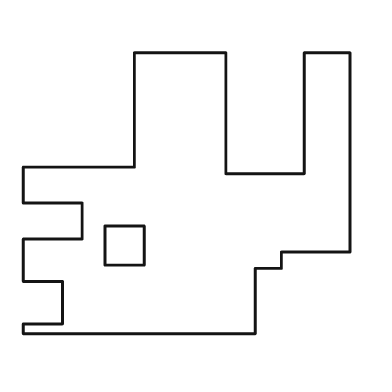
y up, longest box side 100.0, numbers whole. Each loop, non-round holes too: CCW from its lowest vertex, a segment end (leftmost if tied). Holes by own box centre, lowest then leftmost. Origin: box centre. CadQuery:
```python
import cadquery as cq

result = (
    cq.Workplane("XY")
    .moveTo(-50.0, -43.0)
    .lineTo(21.0, -43.0)
    .lineTo(21.0, -23.0)
    .lineTo(29.0, -23.0)
    .lineTo(29.0, -18.0)
    .lineTo(50.0, -18.0)
    .lineTo(50.0, 43.0)
    .lineTo(36.0, 43.0)
    .lineTo(36.0, 6.0)
    .lineTo(12.0, 6.0)
    .lineTo(12.0, 43.0)
    .lineTo(-16.0, 43.0)
    .lineTo(-16.0, 8.0)
    .lineTo(-50.0, 8.0)
    .lineTo(-50.0, -3.0)
    .lineTo(-32.0, -3.0)
    .lineTo(-32.0, -14.0)
    .lineTo(-50.0, -14.0)
    .lineTo(-50.0, -27.0)
    .lineTo(-38.0, -27.0)
    .lineTo(-38.0, -40.0)
    .lineTo(-50.0, -40.0)
    .close()
    .moveTo(-25.0, -22.0)
    .lineTo(-13.0, -22.0)
    .lineTo(-13.0, -10.0)
    .lineTo(-25.0, -10.0)
    .close()
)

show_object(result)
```